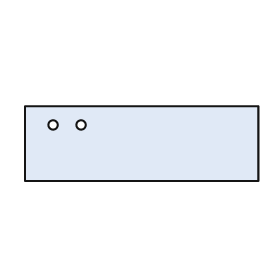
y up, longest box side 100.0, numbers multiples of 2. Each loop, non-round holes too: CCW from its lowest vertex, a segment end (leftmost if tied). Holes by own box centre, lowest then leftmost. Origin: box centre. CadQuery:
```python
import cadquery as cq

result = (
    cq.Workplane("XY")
    .moveTo(-50.0, -16.0)
    .lineTo(50.0, -16.0)
    .lineTo(50.0, 16.0)
    .lineTo(-50.0, 16.0)
    .close()
    .moveTo(-38.0, 8.0)
    .circle(2.0)
    .moveTo(-26.0, 8.0)
    .circle(2.0)
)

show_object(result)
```